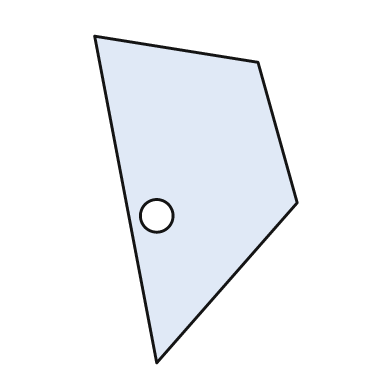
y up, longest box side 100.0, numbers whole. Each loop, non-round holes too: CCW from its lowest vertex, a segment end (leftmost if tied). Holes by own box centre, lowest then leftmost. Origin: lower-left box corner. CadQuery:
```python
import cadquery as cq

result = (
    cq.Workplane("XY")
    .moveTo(19.0, 0.0)
    .lineTo(62.0, 49.0)
    .lineTo(50.0, 92.0)
    .lineTo(0.0, 100.0)
    .close()
    .moveTo(19.0, 45.0)
    .circle(5.0)
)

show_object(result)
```